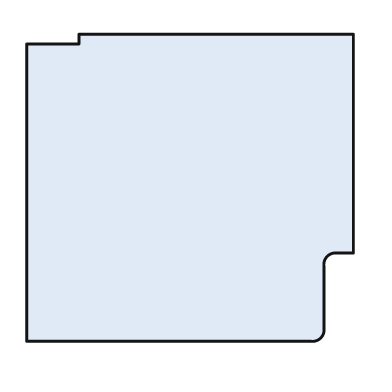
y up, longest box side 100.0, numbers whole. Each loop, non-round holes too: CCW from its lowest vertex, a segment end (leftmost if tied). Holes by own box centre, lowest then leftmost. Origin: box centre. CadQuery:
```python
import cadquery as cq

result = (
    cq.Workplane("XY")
    .moveTo(-50.0, -47.0)
    .lineTo(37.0, -47.0)
    .threePointArc((40.0, -46.0), (41.0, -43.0))
    .lineTo(41.0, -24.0)
    .threePointArc((42.0, -21.0), (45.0, -20.0))
    .lineTo(50.0, -20.0)
    .lineTo(50.0, 47.0)
    .lineTo(-34.0, 47.0)
    .lineTo(-34.0, 44.0)
    .lineTo(-50.0, 44.0)
    .close()
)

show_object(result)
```